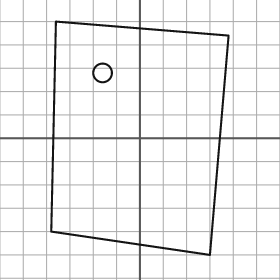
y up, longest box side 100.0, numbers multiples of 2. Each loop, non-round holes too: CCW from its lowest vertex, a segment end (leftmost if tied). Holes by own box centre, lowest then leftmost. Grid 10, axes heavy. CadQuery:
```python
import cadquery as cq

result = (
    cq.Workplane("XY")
    .moveTo(30.0, -50.0)
    .lineTo(38.0, 44.0)
    .lineTo(-36.0, 50.0)
    .lineTo(-38.0, -40.0)
    .close()
    .moveTo(-16.0, 28.0)
    .circle(4.0)
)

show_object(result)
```